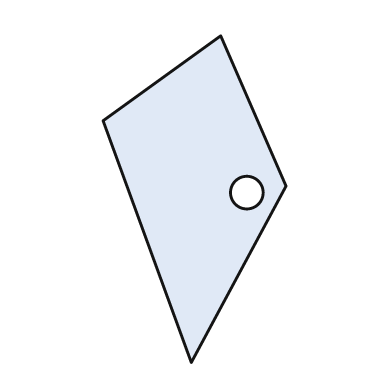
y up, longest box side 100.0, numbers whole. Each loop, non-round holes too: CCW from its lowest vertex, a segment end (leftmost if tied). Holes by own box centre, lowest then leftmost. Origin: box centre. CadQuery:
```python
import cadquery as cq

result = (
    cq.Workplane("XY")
    .moveTo(-1.0, -50.0)
    .lineTo(28.0, 4.0)
    .lineTo(8.0, 50.0)
    .lineTo(-28.0, 24.0)
    .close()
    .moveTo(16.0, 2.0)
    .circle(5.0)
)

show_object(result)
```